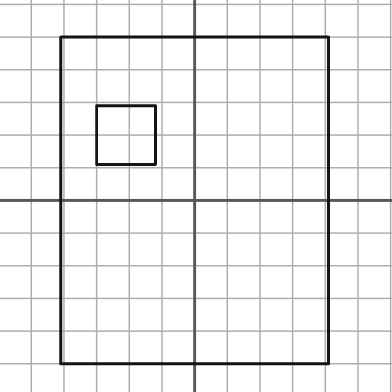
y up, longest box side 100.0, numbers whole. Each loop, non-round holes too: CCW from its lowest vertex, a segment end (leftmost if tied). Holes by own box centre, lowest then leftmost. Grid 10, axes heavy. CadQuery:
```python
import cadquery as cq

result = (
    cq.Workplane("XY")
    .moveTo(-41.0, -50.0)
    .lineTo(41.0, -50.0)
    .lineTo(41.0, 50.0)
    .lineTo(-41.0, 50.0)
    .close()
    .moveTo(-30.0, 11.0)
    .lineTo(-12.0, 11.0)
    .lineTo(-12.0, 29.0)
    .lineTo(-30.0, 29.0)
    .close()
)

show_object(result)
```